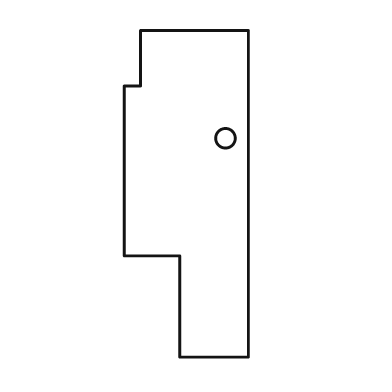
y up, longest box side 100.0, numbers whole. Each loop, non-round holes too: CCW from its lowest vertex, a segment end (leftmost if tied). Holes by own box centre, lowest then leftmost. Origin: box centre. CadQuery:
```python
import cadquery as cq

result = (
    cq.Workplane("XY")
    .moveTo(-2.0, -50.0)
    .lineTo(19.0, -50.0)
    .lineTo(19.0, 50.0)
    .lineTo(-14.0, 50.0)
    .lineTo(-14.0, 33.0)
    .lineTo(-19.0, 33.0)
    .lineTo(-19.0, -19.0)
    .lineTo(-2.0, -19.0)
    .close()
    .moveTo(12.0, 17.0)
    .circle(3.0)
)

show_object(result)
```